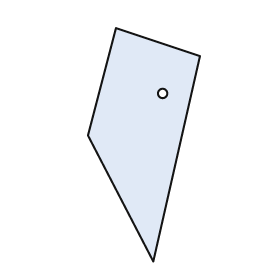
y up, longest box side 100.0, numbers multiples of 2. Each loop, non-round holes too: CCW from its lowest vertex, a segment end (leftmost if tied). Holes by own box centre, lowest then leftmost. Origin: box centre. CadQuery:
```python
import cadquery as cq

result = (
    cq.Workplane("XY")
    .moveTo(4.0, -50.0)
    .lineTo(24.0, 38.0)
    .lineTo(-12.0, 50.0)
    .lineTo(-24.0, 4.0)
    .close()
    .moveTo(8.0, 22.0)
    .circle(2.0)
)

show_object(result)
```